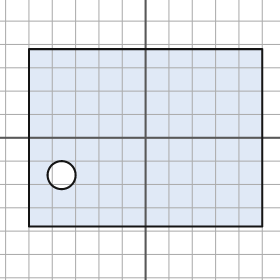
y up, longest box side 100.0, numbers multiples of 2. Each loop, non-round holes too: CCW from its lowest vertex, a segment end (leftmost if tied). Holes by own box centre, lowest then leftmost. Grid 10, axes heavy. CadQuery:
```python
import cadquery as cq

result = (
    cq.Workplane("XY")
    .moveTo(-50.0, -38.0)
    .lineTo(50.0, -38.0)
    .lineTo(50.0, 38.0)
    .lineTo(-50.0, 38.0)
    .close()
    .moveTo(-36.0, -16.0)
    .circle(6.0)
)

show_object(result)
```